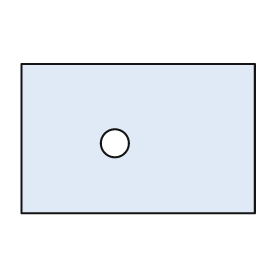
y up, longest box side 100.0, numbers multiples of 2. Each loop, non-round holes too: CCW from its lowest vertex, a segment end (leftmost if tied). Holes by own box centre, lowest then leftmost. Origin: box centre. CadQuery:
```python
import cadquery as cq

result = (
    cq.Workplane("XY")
    .moveTo(-50.0, -32.0)
    .lineTo(50.0, -32.0)
    .lineTo(50.0, 32.0)
    .lineTo(-50.0, 32.0)
    .close()
    .moveTo(-10.0, -2.0)
    .circle(6.0)
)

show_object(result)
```